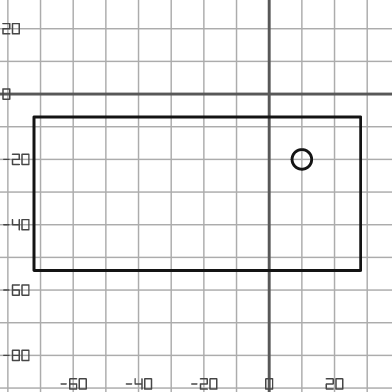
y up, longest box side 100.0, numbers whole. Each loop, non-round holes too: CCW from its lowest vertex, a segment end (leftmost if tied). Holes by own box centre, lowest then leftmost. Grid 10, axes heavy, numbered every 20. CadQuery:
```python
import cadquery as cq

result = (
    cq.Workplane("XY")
    .moveTo(-72.0, -54.0)
    .lineTo(28.0, -54.0)
    .lineTo(28.0, -7.0)
    .lineTo(-72.0, -7.0)
    .close()
    .moveTo(10.0, -20.0)
    .circle(3.0)
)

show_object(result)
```